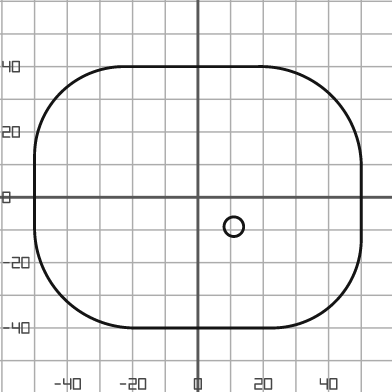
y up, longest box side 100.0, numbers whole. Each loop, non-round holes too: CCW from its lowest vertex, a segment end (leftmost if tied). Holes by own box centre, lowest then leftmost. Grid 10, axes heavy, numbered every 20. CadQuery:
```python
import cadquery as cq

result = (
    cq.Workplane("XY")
    .moveTo(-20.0, -40.0)
    .lineTo(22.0, -40.0)
    .threePointArc((42.0, -32.0), (50.0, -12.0))
    .lineTo(50.0, 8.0)
    .threePointArc((41.0, 31.0), (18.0, 40.0))
    .lineTo(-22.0, 40.0)
    .threePointArc((-42.0, 32.0), (-50.0, 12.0))
    .lineTo(-50.0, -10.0)
    .threePointArc((-41.0, -31.0), (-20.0, -40.0))
    .close()
    .moveTo(11.0, -9.0)
    .circle(3.0)
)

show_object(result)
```